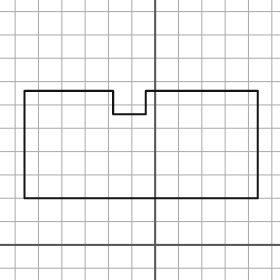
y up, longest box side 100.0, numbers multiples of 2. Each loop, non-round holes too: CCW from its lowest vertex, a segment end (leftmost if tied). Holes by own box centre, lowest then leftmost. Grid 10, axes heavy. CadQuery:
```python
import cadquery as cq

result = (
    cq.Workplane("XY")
    .moveTo(-56.0, 20.0)
    .lineTo(44.0, 20.0)
    .lineTo(44.0, 66.0)
    .lineTo(-4.0, 66.0)
    .lineTo(-4.0, 56.0)
    .lineTo(-18.0, 56.0)
    .lineTo(-18.0, 66.0)
    .lineTo(-56.0, 66.0)
    .close()
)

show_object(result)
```